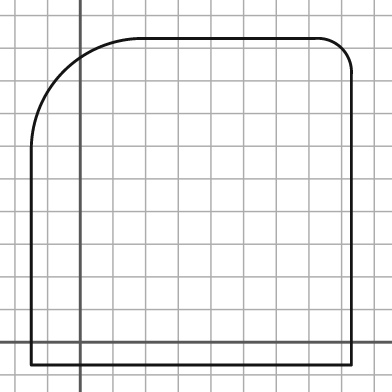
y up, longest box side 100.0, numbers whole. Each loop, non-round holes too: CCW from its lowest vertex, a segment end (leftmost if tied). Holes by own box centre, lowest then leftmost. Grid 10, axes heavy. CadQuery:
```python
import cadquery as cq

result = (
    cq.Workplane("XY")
    .moveTo(-15.0, -7.0)
    .lineTo(83.0, -7.0)
    .lineTo(83.0, 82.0)
    .threePointArc((80.0, 90.0), (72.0, 93.0))
    .lineTo(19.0, 93.0)
    .threePointArc((-5.0, 83.0), (-15.0, 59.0))
    .close()
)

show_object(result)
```